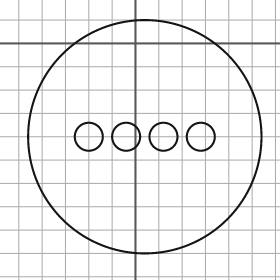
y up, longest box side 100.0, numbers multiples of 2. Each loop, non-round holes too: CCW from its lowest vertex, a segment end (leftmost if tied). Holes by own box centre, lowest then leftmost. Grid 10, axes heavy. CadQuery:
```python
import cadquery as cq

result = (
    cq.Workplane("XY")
    .moveTo(4.0, -40.0)
    .circle(50.0)
    .moveTo(-20.0, -40.0)
    .circle(6.0)
    .moveTo(-4.0, -40.0)
    .circle(6.0)
    .moveTo(12.0, -40.0)
    .circle(6.0)
    .moveTo(28.0, -40.0)
    .circle(6.0)
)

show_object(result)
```